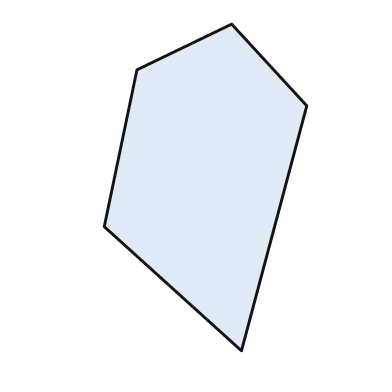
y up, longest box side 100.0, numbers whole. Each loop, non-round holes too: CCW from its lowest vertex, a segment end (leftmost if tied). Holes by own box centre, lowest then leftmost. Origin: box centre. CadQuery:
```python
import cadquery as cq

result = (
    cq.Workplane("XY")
    .moveTo(11.0, -50.0)
    .lineTo(31.0, 25.0)
    .lineTo(8.0, 50.0)
    .lineTo(-21.0, 36.0)
    .lineTo(-31.0, -12.0)
    .close()
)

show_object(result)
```